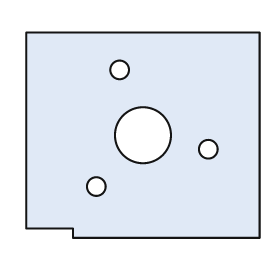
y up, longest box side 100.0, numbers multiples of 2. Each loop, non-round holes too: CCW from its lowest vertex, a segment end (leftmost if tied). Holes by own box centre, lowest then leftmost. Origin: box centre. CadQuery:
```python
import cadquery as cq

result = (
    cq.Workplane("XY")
    .moveTo(-30.0, -44.0)
    .lineTo(50.0, -44.0)
    .lineTo(50.0, 44.0)
    .lineTo(-50.0, 44.0)
    .lineTo(-50.0, -40.0)
    .lineTo(-30.0, -40.0)
    .close()
    .moveTo(-20.0, -22.0)
    .circle(4.0)
    .moveTo(28.0, -6.0)
    .circle(4.0)
    .moveTo(0.0, 0.0)
    .circle(12.0)
    .moveTo(-10.0, 28.0)
    .circle(4.0)
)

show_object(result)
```